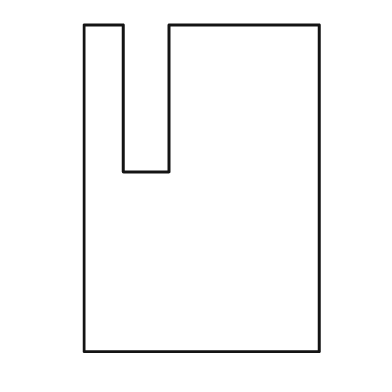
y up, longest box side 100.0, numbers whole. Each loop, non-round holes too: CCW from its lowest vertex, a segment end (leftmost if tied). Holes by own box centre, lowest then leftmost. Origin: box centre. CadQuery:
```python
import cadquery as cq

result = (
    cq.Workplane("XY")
    .moveTo(-36.0, -50.0)
    .lineTo(36.0, -50.0)
    .lineTo(36.0, 50.0)
    .lineTo(-10.0, 50.0)
    .lineTo(-10.0, 5.0)
    .lineTo(-24.0, 5.0)
    .lineTo(-24.0, 50.0)
    .lineTo(-36.0, 50.0)
    .close()
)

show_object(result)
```